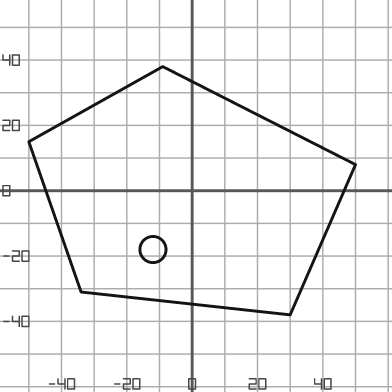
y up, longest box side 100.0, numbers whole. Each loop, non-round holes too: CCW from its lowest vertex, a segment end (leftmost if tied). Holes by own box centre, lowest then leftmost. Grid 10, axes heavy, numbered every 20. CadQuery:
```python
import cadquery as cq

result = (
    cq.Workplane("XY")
    .moveTo(30.0, -38.0)
    .lineTo(50.0, 8.0)
    .lineTo(-9.0, 38.0)
    .lineTo(-50.0, 15.0)
    .lineTo(-34.0, -31.0)
    .close()
    .moveTo(-12.0, -18.0)
    .circle(4.0)
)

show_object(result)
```